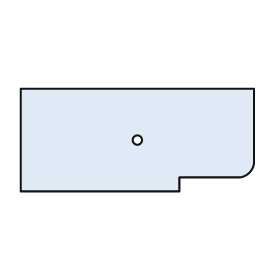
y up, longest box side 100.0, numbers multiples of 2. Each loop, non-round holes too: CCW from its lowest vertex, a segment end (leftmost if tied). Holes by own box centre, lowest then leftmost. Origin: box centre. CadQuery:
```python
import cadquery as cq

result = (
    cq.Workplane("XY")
    .moveTo(-50.0, -22.0)
    .lineTo(18.0, -22.0)
    .lineTo(18.0, -16.0)
    .lineTo(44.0, -16.0)
    .threePointArc((48.0, -14.0), (50.0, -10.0))
    .lineTo(50.0, 22.0)
    .lineTo(-50.0, 22.0)
    .close()
    .moveTo(0.0, 0.0)
    .circle(2.0)
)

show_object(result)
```